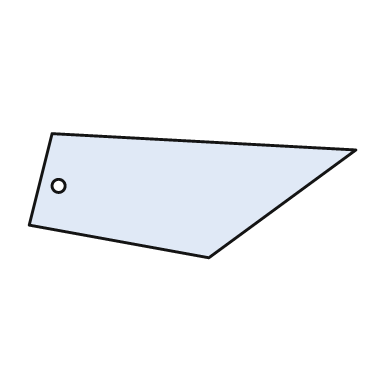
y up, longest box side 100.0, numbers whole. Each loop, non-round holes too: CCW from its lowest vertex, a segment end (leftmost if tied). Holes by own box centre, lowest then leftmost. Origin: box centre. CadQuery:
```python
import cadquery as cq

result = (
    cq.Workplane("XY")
    .moveTo(5.0, -19.0)
    .lineTo(50.0, 14.0)
    .lineTo(-43.0, 19.0)
    .lineTo(-50.0, -9.0)
    .close()
    .moveTo(-41.0, 3.0)
    .circle(2.0)
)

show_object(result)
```